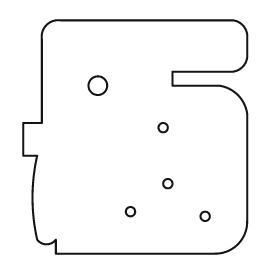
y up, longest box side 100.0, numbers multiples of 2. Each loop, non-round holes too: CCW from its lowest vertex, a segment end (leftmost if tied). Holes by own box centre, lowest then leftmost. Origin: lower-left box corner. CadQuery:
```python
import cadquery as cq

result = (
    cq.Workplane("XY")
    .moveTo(14.0, 0.0)
    .lineTo(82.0, 0.0)
    .threePointArc((92.0, 4.0), (96.0, 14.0))
    .lineTo(96.0, 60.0)
    .threePointArc((92.0, 68.0), (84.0, 72.0))
    .lineTo(64.0, 72.0)
    .lineTo(64.0, 78.0)
    .lineTo(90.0, 78.0)
    .threePointArc((94.0, 80.0), (96.0, 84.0))
    .lineTo(96.0, 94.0)
    .threePointArc((94.0, 98.0), (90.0, 100.0))
    .lineTo(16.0, 100.0)
    .threePointArc((10.0, 98.0), (8.0, 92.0))
    .lineTo(8.0, 56.0)
    .lineTo(0.0, 56.0)
    .lineTo(0.0, 42.0)
    .lineTo(6.0, 42.0)
    .threePointArc((4.0, 24.0), (6.0, 6.0))
    .threePointArc((10.0, 4.0), (14.0, 6.0))
    .close()
    .moveTo(78.0, 16.0)
    .circle(2.0)
    .moveTo(46.0, 18.0)
    .circle(2.0)
    .moveTo(62.0, 30.0)
    .circle(2.0)
    .moveTo(60.0, 54.0)
    .circle(2.0)
    .moveTo(32.0, 72.0)
    .circle(4.0)
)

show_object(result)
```